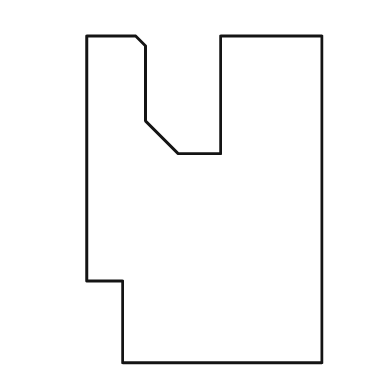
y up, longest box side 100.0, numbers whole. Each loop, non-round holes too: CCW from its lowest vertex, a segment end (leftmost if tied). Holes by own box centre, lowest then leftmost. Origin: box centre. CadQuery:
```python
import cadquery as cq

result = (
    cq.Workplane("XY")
    .moveTo(-25.0, -50.0)
    .lineTo(36.0, -50.0)
    .lineTo(36.0, 50.0)
    .lineTo(5.0, 50.0)
    .lineTo(5.0, 14.0)
    .lineTo(-8.0, 14.0)
    .lineTo(-18.0, 24.0)
    .lineTo(-18.0, 47.0)
    .lineTo(-21.0, 50.0)
    .lineTo(-36.0, 50.0)
    .lineTo(-36.0, -25.0)
    .lineTo(-25.0, -25.0)
    .close()
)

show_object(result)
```